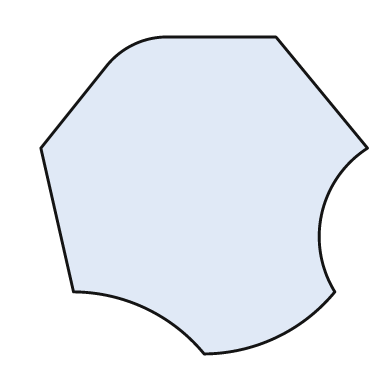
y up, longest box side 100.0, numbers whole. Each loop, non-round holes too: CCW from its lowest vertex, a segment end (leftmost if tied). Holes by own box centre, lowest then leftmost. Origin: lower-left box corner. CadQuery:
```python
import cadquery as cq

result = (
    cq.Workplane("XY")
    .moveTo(50.0, 0.0)
    .threePointArc((72.0, 5.0), (90.0, 19.0))
    .threePointArc((86.0, 43.0), (100.0, 63.0))
    .lineTo(72.0, 97.0)
    .lineTo(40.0, 97.0)
    .threePointArc((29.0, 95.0), (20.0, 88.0))
    .lineTo(0.0, 63.0)
    .lineTo(10.0, 19.0)
    .threePointArc((32.0, 14.0), (50.0, 0.0))
    .close()
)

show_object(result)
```